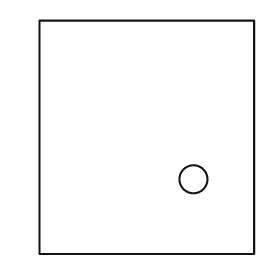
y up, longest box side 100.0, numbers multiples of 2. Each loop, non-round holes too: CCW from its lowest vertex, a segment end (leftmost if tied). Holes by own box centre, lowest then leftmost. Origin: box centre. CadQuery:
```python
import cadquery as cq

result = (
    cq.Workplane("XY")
    .moveTo(-46.0, -50.0)
    .lineTo(46.0, -50.0)
    .lineTo(46.0, 50.0)
    .lineTo(-46.0, 50.0)
    .close()
    .moveTo(20.0, -18.0)
    .circle(6.0)
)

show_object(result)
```